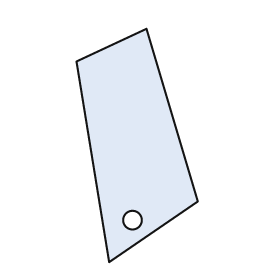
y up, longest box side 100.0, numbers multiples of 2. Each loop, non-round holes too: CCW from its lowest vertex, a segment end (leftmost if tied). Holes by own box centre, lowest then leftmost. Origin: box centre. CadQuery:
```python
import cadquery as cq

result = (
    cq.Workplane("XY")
    .moveTo(-12.0, -50.0)
    .lineTo(26.0, -24.0)
    .lineTo(4.0, 50.0)
    .lineTo(-26.0, 36.0)
    .close()
    .moveTo(-2.0, -32.0)
    .circle(4.0)
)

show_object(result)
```